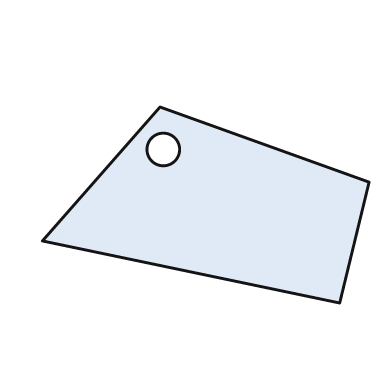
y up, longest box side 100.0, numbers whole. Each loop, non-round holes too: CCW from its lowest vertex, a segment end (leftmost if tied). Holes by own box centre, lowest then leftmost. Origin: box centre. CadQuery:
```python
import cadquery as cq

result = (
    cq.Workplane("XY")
    .moveTo(41.0, -30.0)
    .lineTo(50.0, 7.0)
    .lineTo(-14.0, 30.0)
    .lineTo(-50.0, -11.0)
    .close()
    .moveTo(-13.0, 17.0)
    .circle(5.0)
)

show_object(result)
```